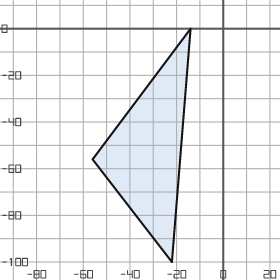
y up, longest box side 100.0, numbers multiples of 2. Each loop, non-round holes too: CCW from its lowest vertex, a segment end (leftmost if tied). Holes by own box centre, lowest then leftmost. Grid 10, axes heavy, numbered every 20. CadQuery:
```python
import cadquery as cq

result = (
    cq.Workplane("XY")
    .moveTo(-22.0, -100.0)
    .lineTo(-14.0, 0.0)
    .lineTo(-56.0, -56.0)
    .close()
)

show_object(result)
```